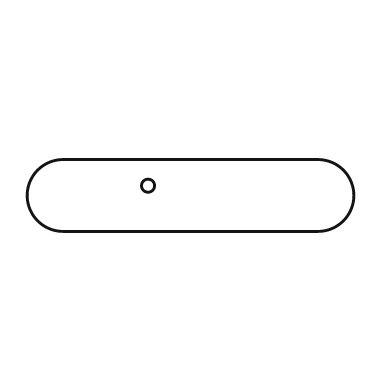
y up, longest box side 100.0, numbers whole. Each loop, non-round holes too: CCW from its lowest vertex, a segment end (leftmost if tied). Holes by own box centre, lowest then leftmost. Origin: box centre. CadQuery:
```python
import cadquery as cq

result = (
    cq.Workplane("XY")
    .moveTo(-39.0, -11.0)
    .lineTo(39.0, -11.0)
    .threePointArc((50.0, 0.0), (39.0, 11.0))
    .lineTo(-39.0, 11.0)
    .threePointArc((-50.0, 0.0), (-39.0, -11.0))
    .close()
    .moveTo(-13.0, 3.0)
    .circle(2.0)
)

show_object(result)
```